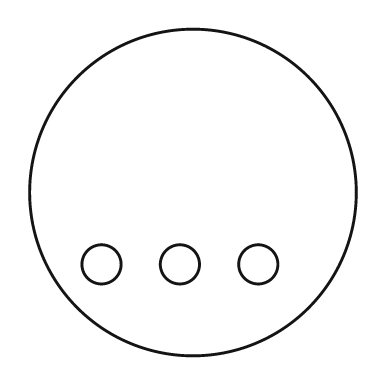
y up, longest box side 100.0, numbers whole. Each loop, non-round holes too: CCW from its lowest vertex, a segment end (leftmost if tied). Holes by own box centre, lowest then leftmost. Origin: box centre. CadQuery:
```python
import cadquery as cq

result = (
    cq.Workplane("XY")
    .moveTo(0.0, 0.0)
    .circle(50.0)
    .moveTo(-28.0, -22.0)
    .circle(6.0)
    .moveTo(-4.0, -22.0)
    .circle(6.0)
    .moveTo(20.0, -22.0)
    .circle(6.0)
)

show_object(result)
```